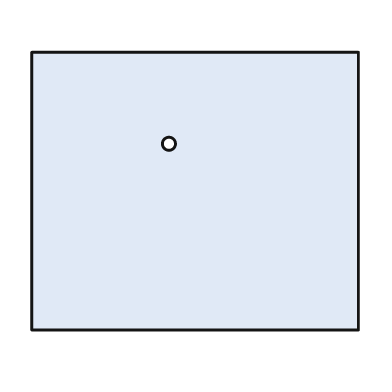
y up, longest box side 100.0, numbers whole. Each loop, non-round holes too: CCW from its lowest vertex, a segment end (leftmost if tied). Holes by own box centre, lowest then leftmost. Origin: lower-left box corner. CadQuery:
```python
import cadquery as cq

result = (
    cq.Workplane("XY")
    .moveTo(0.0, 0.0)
    .lineTo(100.0, 0.0)
    .lineTo(100.0, 85.0)
    .lineTo(0.0, 85.0)
    .close()
    .moveTo(42.0, 57.0)
    .circle(2.0)
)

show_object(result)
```